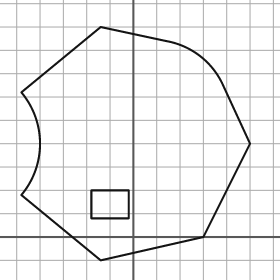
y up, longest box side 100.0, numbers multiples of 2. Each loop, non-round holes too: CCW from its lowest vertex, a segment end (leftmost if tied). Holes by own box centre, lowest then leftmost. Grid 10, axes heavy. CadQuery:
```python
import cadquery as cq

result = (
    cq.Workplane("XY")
    .moveTo(-14.0, -10.0)
    .lineTo(30.0, 0.0)
    .lineTo(50.0, 40.0)
    .lineTo(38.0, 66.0)
    .threePointArc((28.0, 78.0), (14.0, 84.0))
    .lineTo(-14.0, 90.0)
    .lineTo(-48.0, 62.0)
    .threePointArc((-40.0, 40.0), (-48.0, 18.0))
    .close()
    .moveTo(-18.0, 8.0)
    .lineTo(-2.0, 8.0)
    .lineTo(-2.0, 20.0)
    .lineTo(-18.0, 20.0)
    .close()
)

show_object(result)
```